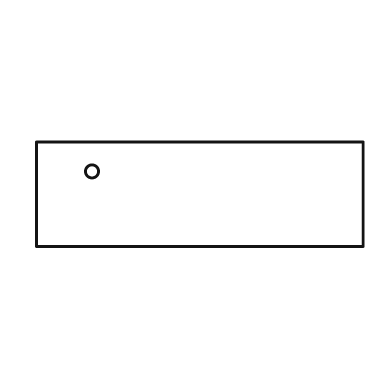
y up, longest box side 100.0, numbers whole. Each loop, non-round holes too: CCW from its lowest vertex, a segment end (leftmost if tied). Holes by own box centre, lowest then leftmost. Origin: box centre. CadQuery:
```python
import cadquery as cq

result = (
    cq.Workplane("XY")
    .moveTo(-50.0, -16.0)
    .lineTo(50.0, -16.0)
    .lineTo(50.0, 16.0)
    .lineTo(-50.0, 16.0)
    .close()
    .moveTo(-33.0, 7.0)
    .circle(2.0)
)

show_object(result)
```